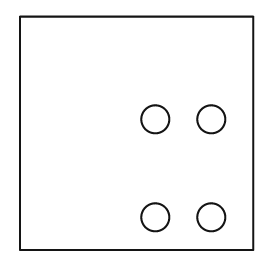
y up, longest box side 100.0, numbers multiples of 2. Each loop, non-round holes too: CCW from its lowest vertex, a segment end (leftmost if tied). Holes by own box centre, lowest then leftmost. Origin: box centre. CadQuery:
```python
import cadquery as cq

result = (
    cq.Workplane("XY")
    .moveTo(-50.0, -50.0)
    .lineTo(50.0, -50.0)
    .lineTo(50.0, 50.0)
    .lineTo(-50.0, 50.0)
    .close()
    .moveTo(8.0, -36.0)
    .circle(6.0)
    .moveTo(32.0, -36.0)
    .circle(6.0)
    .moveTo(8.0, 6.0)
    .circle(6.0)
    .moveTo(32.0, 6.0)
    .circle(6.0)
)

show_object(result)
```